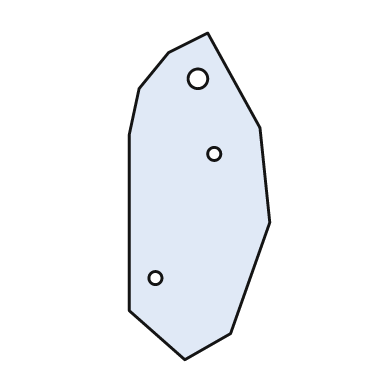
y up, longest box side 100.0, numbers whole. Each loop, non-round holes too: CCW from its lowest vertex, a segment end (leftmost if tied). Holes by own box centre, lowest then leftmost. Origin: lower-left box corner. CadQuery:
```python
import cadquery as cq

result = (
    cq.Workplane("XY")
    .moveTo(17.0, 0.0)
    .lineTo(31.0, 8.0)
    .lineTo(43.0, 42.0)
    .lineTo(40.0, 71.0)
    .lineTo(24.0, 100.0)
    .lineTo(12.0, 94.0)
    .lineTo(3.0, 83.0)
    .lineTo(0.0, 69.0)
    .lineTo(0.0, 15.0)
    .close()
    .moveTo(8.0, 25.0)
    .circle(2.0)
    .moveTo(26.0, 63.0)
    .circle(2.0)
    .moveTo(21.0, 86.0)
    .circle(3.0)
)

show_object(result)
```